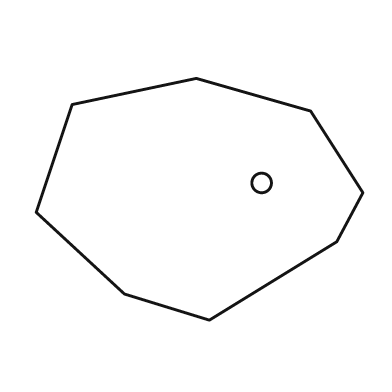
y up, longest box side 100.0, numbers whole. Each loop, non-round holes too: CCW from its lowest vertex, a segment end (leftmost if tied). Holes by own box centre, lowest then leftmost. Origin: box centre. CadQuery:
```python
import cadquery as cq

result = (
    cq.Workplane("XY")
    .moveTo(3.0, -37.0)
    .lineTo(42.0, -13.0)
    .lineTo(50.0, 2.0)
    .lineTo(34.0, 27.0)
    .lineTo(-1.0, 37.0)
    .lineTo(-39.0, 29.0)
    .lineTo(-50.0, -4.0)
    .lineTo(-23.0, -29.0)
    .close()
    .moveTo(19.0, 5.0)
    .circle(3.0)
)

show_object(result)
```